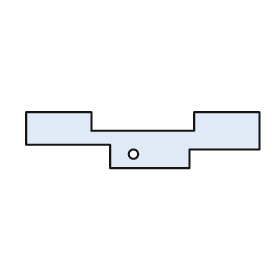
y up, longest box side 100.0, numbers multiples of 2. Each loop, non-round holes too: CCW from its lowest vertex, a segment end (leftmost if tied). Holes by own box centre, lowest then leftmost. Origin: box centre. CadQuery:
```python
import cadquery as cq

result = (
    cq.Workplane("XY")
    .moveTo(-14.0, -12.0)
    .lineTo(20.0, -12.0)
    .lineTo(20.0, -4.0)
    .lineTo(50.0, -4.0)
    .lineTo(50.0, 12.0)
    .lineTo(22.0, 12.0)
    .lineTo(22.0, 4.0)
    .lineTo(-22.0, 4.0)
    .lineTo(-22.0, 12.0)
    .lineTo(-50.0, 12.0)
    .lineTo(-50.0, -2.0)
    .lineTo(-14.0, -2.0)
    .close()
    .moveTo(-4.0, -6.0)
    .circle(2.0)
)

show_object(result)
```